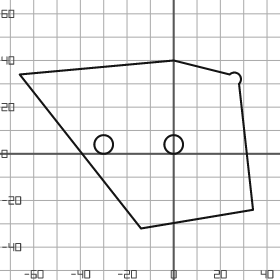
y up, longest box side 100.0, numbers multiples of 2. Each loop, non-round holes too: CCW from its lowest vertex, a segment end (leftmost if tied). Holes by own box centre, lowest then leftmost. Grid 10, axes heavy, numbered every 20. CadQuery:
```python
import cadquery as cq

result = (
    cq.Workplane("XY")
    .moveTo(-14.0, -32.0)
    .lineTo(34.0, -24.0)
    .lineTo(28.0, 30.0)
    .threePointArc((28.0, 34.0), (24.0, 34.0))
    .lineTo(0.0, 40.0)
    .lineTo(-66.0, 34.0)
    .close()
    .moveTo(-30.0, 4.0)
    .circle(4.0)
    .moveTo(0.0, 4.0)
    .circle(4.0)
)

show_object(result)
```